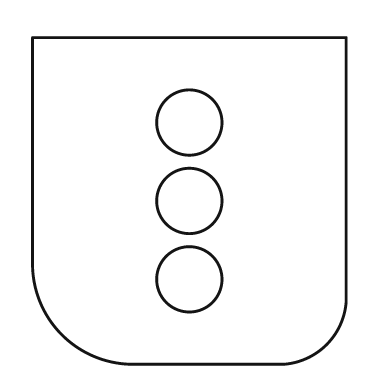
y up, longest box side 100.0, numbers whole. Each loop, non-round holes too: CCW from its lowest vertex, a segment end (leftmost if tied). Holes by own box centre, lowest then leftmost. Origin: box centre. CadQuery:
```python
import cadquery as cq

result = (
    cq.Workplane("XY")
    .moveTo(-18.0, -50.0)
    .lineTo(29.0, -50.0)
    .threePointArc((42.0, -44.0), (48.0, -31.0))
    .lineTo(48.0, 50.0)
    .lineTo(-48.0, 50.0)
    .lineTo(-48.0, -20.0)
    .threePointArc((-39.0, -41.0), (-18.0, -50.0))
    .close()
    .moveTo(0.0, -24.0)
    .circle(10.0)
    .moveTo(0.0, 0.0)
    .circle(10.0)
    .moveTo(0.0, 24.0)
    .circle(10.0)
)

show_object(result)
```